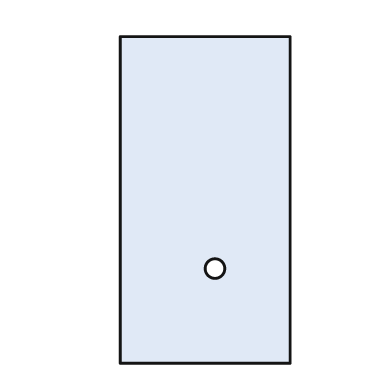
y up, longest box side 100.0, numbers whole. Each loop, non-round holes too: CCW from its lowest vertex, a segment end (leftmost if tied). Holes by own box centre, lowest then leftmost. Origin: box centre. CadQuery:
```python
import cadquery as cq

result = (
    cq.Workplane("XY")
    .moveTo(-26.0, -50.0)
    .lineTo(26.0, -50.0)
    .lineTo(26.0, 50.0)
    .lineTo(-26.0, 50.0)
    .close()
    .moveTo(3.0, -21.0)
    .circle(3.0)
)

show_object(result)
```